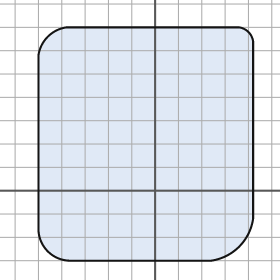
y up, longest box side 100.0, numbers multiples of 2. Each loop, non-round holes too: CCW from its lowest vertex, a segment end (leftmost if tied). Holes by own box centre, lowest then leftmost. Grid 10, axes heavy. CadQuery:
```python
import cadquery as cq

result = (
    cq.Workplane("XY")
    .moveTo(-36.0, -30.0)
    .lineTo(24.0, -30.0)
    .threePointArc((36.0, -24.0), (42.0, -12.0))
    .lineTo(42.0, 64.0)
    .threePointArc((40.0, 68.0), (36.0, 70.0))
    .lineTo(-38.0, 70.0)
    .threePointArc((-46.0, 66.0), (-50.0, 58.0))
    .lineTo(-50.0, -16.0)
    .threePointArc((-46.0, -26.0), (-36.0, -30.0))
    .close()
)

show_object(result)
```